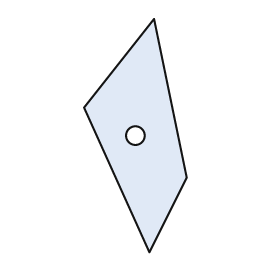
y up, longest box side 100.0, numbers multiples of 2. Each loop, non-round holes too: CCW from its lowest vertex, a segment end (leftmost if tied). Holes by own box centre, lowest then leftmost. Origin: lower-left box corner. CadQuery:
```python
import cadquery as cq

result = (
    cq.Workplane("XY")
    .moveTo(28.0, 0.0)
    .lineTo(44.0, 32.0)
    .lineTo(30.0, 100.0)
    .lineTo(0.0, 62.0)
    .close()
    .moveTo(22.0, 50.0)
    .circle(4.0)
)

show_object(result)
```